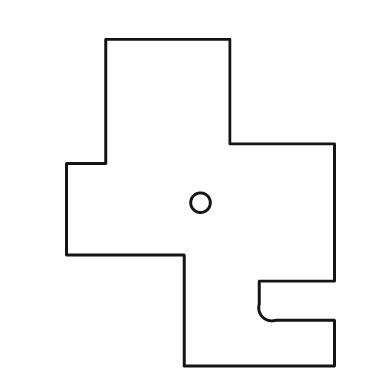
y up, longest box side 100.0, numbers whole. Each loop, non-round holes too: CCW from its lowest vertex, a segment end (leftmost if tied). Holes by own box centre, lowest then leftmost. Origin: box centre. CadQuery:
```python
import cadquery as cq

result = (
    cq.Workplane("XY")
    .moveTo(-5.0, -50.0)
    .lineTo(41.0, -50.0)
    .lineTo(41.0, -36.0)
    .lineTo(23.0, -36.0)
    .threePointArc((19.0, -35.0), (18.0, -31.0))
    .lineTo(18.0, -24.0)
    .lineTo(41.0, -24.0)
    .lineTo(41.0, 18.0)
    .lineTo(9.0, 18.0)
    .lineTo(9.0, 50.0)
    .lineTo(-29.0, 50.0)
    .lineTo(-29.0, 12.0)
    .lineTo(-41.0, 12.0)
    .lineTo(-41.0, -16.0)
    .lineTo(-5.0, -16.0)
    .close()
    .moveTo(0.0, 0.0)
    .circle(3.0)
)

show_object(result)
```